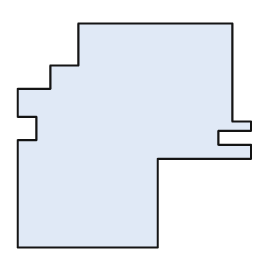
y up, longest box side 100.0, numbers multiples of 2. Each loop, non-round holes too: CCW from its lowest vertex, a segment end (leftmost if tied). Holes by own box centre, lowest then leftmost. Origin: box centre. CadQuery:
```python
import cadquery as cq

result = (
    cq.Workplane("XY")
    .moveTo(-50.0, -48.0)
    .lineTo(10.0, -48.0)
    .lineTo(10.0, -10.0)
    .lineTo(50.0, -10.0)
    .lineTo(50.0, -4.0)
    .lineTo(36.0, -4.0)
    .lineTo(36.0, 2.0)
    .lineTo(50.0, 2.0)
    .lineTo(50.0, 6.0)
    .lineTo(42.0, 6.0)
    .lineTo(42.0, 48.0)
    .lineTo(-24.0, 48.0)
    .lineTo(-24.0, 30.0)
    .lineTo(-36.0, 30.0)
    .lineTo(-36.0, 20.0)
    .lineTo(-50.0, 20.0)
    .lineTo(-50.0, 8.0)
    .lineTo(-42.0, 8.0)
    .lineTo(-42.0, -2.0)
    .lineTo(-50.0, -2.0)
    .close()
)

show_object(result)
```